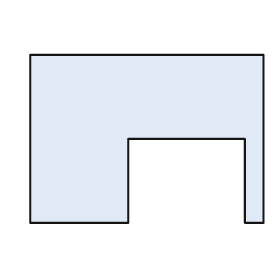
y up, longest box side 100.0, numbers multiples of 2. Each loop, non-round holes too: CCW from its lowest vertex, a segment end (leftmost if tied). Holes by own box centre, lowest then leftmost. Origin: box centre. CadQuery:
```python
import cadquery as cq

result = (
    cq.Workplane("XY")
    .moveTo(-50.0, -36.0)
    .lineTo(-8.0, -36.0)
    .lineTo(-8.0, 0.0)
    .lineTo(42.0, 0.0)
    .lineTo(42.0, -36.0)
    .lineTo(50.0, -36.0)
    .lineTo(50.0, 36.0)
    .lineTo(-50.0, 36.0)
    .close()
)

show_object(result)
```